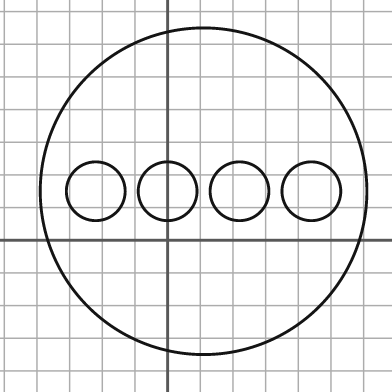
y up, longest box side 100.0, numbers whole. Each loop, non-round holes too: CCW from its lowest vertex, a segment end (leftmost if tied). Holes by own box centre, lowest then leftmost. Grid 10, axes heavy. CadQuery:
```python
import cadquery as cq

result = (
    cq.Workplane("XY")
    .moveTo(11.0, 15.0)
    .circle(50.0)
    .moveTo(-22.0, 15.0)
    .circle(9.0)
    .moveTo(0.0, 15.0)
    .circle(9.0)
    .moveTo(22.0, 15.0)
    .circle(9.0)
    .moveTo(44.0, 15.0)
    .circle(9.0)
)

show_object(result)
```